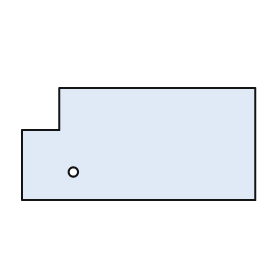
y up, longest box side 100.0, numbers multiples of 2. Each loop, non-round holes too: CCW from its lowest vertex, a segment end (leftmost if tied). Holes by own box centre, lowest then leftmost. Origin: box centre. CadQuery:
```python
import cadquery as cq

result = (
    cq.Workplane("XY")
    .moveTo(-50.0, -24.0)
    .lineTo(50.0, -24.0)
    .lineTo(50.0, 24.0)
    .lineTo(-34.0, 24.0)
    .lineTo(-34.0, 6.0)
    .lineTo(-50.0, 6.0)
    .close()
    .moveTo(-28.0, -12.0)
    .circle(2.0)
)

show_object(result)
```